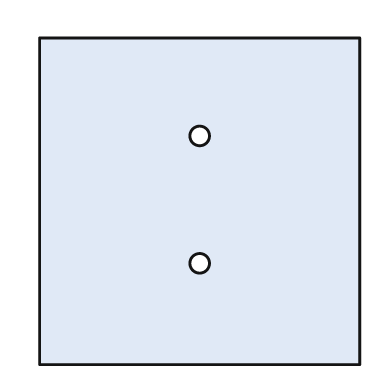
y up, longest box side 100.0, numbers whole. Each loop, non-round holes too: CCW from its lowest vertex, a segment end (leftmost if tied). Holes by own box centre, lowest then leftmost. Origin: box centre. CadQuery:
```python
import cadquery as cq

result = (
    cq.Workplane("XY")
    .moveTo(-49.0, -50.0)
    .lineTo(49.0, -50.0)
    .lineTo(49.0, 50.0)
    .lineTo(-49.0, 50.0)
    .close()
    .moveTo(0.0, -19.0)
    .circle(3.0)
    .moveTo(0.0, 20.0)
    .circle(3.0)
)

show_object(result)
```